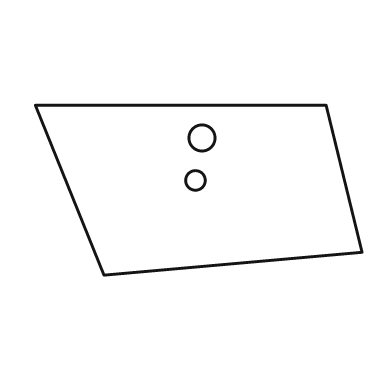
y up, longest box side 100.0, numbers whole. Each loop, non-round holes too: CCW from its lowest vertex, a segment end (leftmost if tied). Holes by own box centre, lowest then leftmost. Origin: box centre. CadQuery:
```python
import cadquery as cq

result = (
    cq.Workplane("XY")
    .moveTo(-29.0, -26.0)
    .lineTo(50.0, -19.0)
    .lineTo(39.0, 26.0)
    .lineTo(-50.0, 26.0)
    .close()
    .moveTo(-1.0, 3.0)
    .circle(3.0)
    .moveTo(1.0, 16.0)
    .circle(4.0)
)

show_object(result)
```